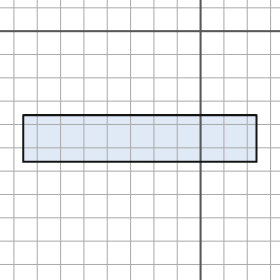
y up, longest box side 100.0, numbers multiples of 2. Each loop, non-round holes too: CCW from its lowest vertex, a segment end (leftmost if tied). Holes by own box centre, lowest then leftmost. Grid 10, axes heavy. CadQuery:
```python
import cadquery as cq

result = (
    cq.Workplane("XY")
    .moveTo(-76.0, -56.0)
    .lineTo(24.0, -56.0)
    .lineTo(24.0, -36.0)
    .lineTo(-76.0, -36.0)
    .close()
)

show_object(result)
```